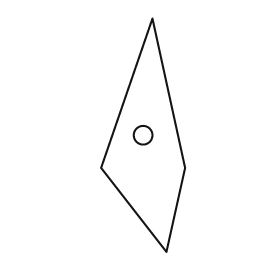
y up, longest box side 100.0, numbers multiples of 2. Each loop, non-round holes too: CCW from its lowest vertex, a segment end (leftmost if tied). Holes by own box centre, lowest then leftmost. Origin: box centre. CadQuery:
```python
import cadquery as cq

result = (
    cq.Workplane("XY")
    .moveTo(10.0, -50.0)
    .lineTo(18.0, -14.0)
    .lineTo(4.0, 50.0)
    .lineTo(-18.0, -14.0)
    .close()
    .moveTo(0.0, 0.0)
    .circle(4.0)
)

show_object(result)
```